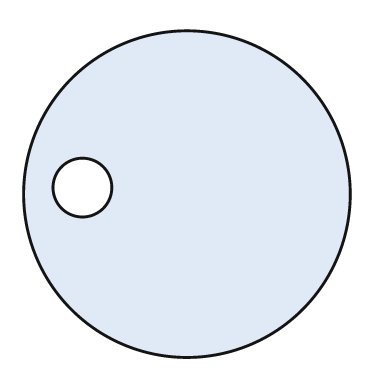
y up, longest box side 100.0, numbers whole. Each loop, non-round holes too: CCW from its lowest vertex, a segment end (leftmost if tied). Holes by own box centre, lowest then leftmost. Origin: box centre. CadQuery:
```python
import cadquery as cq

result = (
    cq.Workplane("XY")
    .moveTo(0.0, 0.0)
    .circle(50.0)
    .moveTo(-32.0, 2.0)
    .circle(9.0)
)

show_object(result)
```